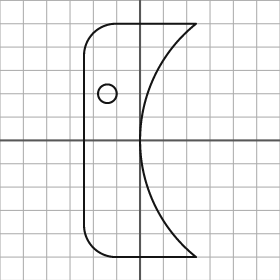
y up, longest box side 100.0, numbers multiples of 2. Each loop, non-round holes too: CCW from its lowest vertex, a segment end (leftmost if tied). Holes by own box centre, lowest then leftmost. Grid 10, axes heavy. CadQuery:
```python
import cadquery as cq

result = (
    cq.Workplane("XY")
    .moveTo(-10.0, -50.0)
    .lineTo(24.0, -50.0)
    .threePointArc((0.0, 0.0), (24.0, 50.0))
    .lineTo(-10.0, 50.0)
    .threePointArc((-20.0, 46.0), (-24.0, 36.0))
    .lineTo(-24.0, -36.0)
    .threePointArc((-20.0, -46.0), (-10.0, -50.0))
    .close()
    .moveTo(-14.0, 20.0)
    .circle(4.0)
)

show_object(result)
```